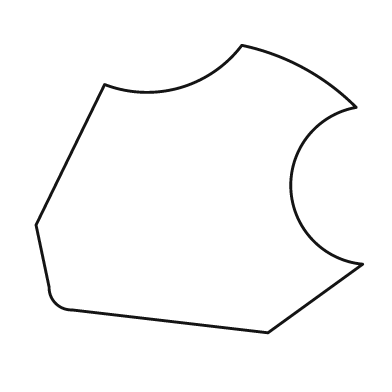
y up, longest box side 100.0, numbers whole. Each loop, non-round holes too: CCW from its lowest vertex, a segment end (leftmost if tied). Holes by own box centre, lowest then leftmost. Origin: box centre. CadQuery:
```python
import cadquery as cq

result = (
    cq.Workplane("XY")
    .moveTo(21.0, -44.0)
    .lineTo(50.0, -23.0)
    .threePointArc((28.0, 0.0), (48.0, 25.0))
    .threePointArc((32.0, 37.0), (13.0, 44.0))
    .threePointArc((-6.0, 31.0), (-29.0, 32.0))
    .lineTo(-50.0, -11.0)
    .lineTo(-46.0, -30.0)
    .threePointArc((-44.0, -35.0), (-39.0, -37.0))
    .close()
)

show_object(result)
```